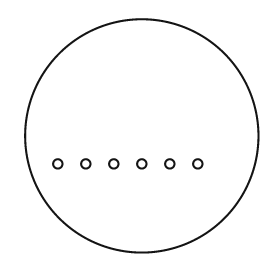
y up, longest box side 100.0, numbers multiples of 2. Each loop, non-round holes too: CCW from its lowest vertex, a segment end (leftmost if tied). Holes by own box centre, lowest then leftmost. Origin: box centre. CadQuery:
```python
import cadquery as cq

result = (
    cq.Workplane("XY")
    .moveTo(0.0, 0.0)
    .circle(50.0)
    .moveTo(-36.0, -12.0)
    .circle(2.0)
    .moveTo(-24.0, -12.0)
    .circle(2.0)
    .moveTo(-12.0, -12.0)
    .circle(2.0)
    .moveTo(0.0, -12.0)
    .circle(2.0)
    .moveTo(12.0, -12.0)
    .circle(2.0)
    .moveTo(24.0, -12.0)
    .circle(2.0)
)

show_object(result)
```